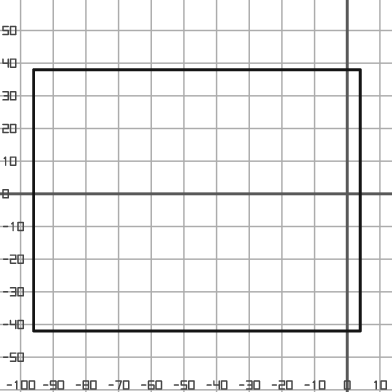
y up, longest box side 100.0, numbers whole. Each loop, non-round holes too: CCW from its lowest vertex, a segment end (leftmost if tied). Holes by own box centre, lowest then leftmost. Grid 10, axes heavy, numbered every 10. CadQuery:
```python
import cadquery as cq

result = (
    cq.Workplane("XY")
    .moveTo(-96.0, -42.0)
    .lineTo(4.0, -42.0)
    .lineTo(4.0, 38.0)
    .lineTo(-96.0, 38.0)
    .close()
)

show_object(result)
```